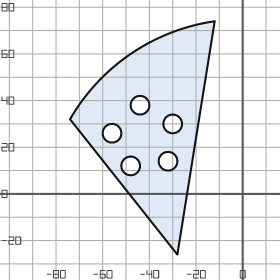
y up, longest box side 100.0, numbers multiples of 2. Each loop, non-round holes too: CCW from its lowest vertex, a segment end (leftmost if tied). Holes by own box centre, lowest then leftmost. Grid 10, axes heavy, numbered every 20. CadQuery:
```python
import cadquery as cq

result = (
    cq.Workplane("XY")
    .moveTo(-28.0, -26.0)
    .lineTo(-12.0, 74.0)
    .threePointArc((-48.0, 60.0), (-74.0, 32.0))
    .close()
    .moveTo(-48.0, 12.0)
    .circle(4.0)
    .moveTo(-32.0, 14.0)
    .circle(4.0)
    .moveTo(-56.0, 26.0)
    .circle(4.0)
    .moveTo(-30.0, 30.0)
    .circle(4.0)
    .moveTo(-44.0, 38.0)
    .circle(4.0)
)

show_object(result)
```